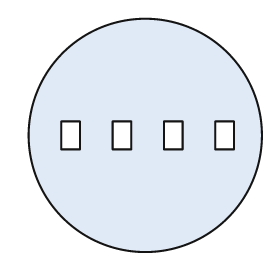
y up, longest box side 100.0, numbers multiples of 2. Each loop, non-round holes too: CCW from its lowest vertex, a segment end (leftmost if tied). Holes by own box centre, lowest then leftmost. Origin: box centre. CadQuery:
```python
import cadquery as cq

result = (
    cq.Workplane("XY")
    .moveTo(0.0, 0.0)
    .circle(50.0)
    .moveTo(-36.0, -6.0)
    .lineTo(-28.0, -6.0)
    .lineTo(-28.0, 6.0)
    .lineTo(-36.0, 6.0)
    .close()
    .moveTo(-14.0, -6.0)
    .lineTo(-6.0, -6.0)
    .lineTo(-6.0, 6.0)
    .lineTo(-14.0, 6.0)
    .close()
    .moveTo(8.0, -6.0)
    .lineTo(16.0, -6.0)
    .lineTo(16.0, 6.0)
    .lineTo(8.0, 6.0)
    .close()
    .moveTo(30.0, -6.0)
    .lineTo(38.0, -6.0)
    .lineTo(38.0, 6.0)
    .lineTo(30.0, 6.0)
    .close()
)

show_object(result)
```